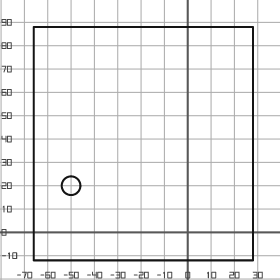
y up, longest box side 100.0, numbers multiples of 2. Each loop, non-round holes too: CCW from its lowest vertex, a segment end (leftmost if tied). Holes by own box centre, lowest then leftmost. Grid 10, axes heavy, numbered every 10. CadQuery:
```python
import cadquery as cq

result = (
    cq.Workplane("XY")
    .moveTo(-66.0, -12.0)
    .lineTo(28.0, -12.0)
    .lineTo(28.0, 88.0)
    .lineTo(-66.0, 88.0)
    .close()
    .moveTo(-50.0, 20.0)
    .circle(4.0)
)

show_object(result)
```